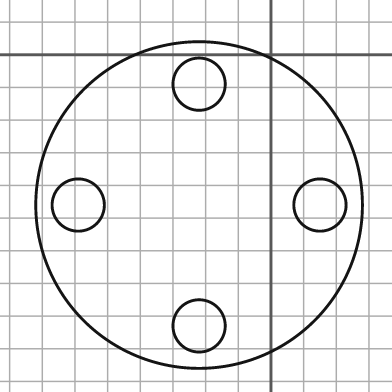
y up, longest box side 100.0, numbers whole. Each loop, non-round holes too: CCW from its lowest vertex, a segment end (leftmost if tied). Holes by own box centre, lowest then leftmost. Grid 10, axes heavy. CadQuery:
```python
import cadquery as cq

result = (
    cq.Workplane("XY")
    .moveTo(-22.0, -46.0)
    .circle(50.0)
    .moveTo(-22.0, -83.0)
    .circle(8.0)
    .moveTo(-59.0, -46.0)
    .circle(8.0)
    .moveTo(15.0, -46.0)
    .circle(8.0)
    .moveTo(-22.0, -9.0)
    .circle(8.0)
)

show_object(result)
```